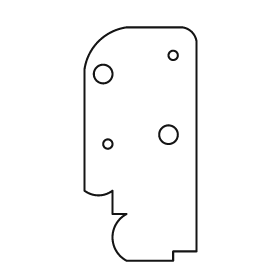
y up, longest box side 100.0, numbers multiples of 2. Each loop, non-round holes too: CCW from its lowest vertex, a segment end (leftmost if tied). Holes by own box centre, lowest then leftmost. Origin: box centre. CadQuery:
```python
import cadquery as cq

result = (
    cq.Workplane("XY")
    .moveTo(-6.0, -50.0)
    .lineTo(14.0, -50.0)
    .lineTo(14.0, -46.0)
    .lineTo(24.0, -46.0)
    .lineTo(24.0, 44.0)
    .threePointArc((22.0, 48.0), (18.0, 50.0))
    .lineTo(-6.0, 50.0)
    .threePointArc((-18.0, 44.0), (-24.0, 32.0))
    .lineTo(-24.0, -20.0)
    .threePointArc((-18.0, -22.0), (-12.0, -20.0))
    .lineTo(-12.0, -30.0)
    .lineTo(-6.0, -30.0)
    .threePointArc((-12.0, -40.0), (-6.0, -50.0))
    .close()
    .moveTo(-14.0, 0.0)
    .circle(2.0)
    .moveTo(12.0, 4.0)
    .circle(4.0)
    .moveTo(-16.0, 30.0)
    .circle(4.0)
    .moveTo(14.0, 38.0)
    .circle(2.0)
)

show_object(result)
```